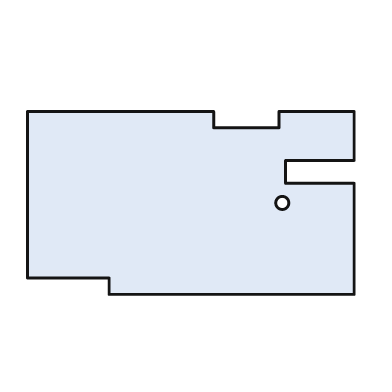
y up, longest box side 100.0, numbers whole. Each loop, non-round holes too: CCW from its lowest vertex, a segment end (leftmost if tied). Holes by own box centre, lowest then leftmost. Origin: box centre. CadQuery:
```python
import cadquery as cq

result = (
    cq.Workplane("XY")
    .moveTo(-25.0, -28.0)
    .lineTo(50.0, -28.0)
    .lineTo(50.0, 6.0)
    .lineTo(29.0, 6.0)
    .lineTo(29.0, 13.0)
    .lineTo(50.0, 13.0)
    .lineTo(50.0, 28.0)
    .lineTo(27.0, 28.0)
    .lineTo(27.0, 23.0)
    .lineTo(7.0, 23.0)
    .lineTo(7.0, 28.0)
    .lineTo(-50.0, 28.0)
    .lineTo(-50.0, -23.0)
    .lineTo(-25.0, -23.0)
    .close()
    .moveTo(28.0, 0.0)
    .circle(2.0)
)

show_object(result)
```